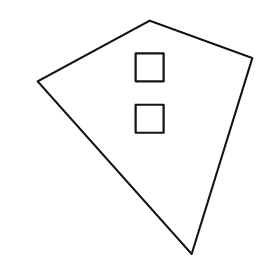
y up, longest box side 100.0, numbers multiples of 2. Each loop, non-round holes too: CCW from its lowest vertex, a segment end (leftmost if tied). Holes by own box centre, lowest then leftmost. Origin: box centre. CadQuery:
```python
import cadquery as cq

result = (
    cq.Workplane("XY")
    .moveTo(20.0, -50.0)
    .lineTo(46.0, 34.0)
    .lineTo(2.0, 50.0)
    .lineTo(-46.0, 24.0)
    .close()
    .moveTo(-4.0, 2.0)
    .lineTo(8.0, 2.0)
    .lineTo(8.0, 14.0)
    .lineTo(-4.0, 14.0)
    .close()
    .moveTo(-4.0, 24.0)
    .lineTo(8.0, 24.0)
    .lineTo(8.0, 36.0)
    .lineTo(-4.0, 36.0)
    .close()
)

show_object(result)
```